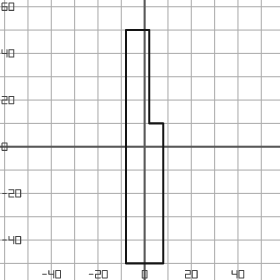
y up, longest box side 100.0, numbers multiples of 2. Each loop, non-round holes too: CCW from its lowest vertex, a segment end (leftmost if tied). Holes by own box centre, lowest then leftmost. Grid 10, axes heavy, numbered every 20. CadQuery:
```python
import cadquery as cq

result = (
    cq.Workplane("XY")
    .moveTo(-8.0, -50.0)
    .lineTo(8.0, -50.0)
    .lineTo(8.0, 10.0)
    .lineTo(2.0, 10.0)
    .lineTo(2.0, 50.0)
    .lineTo(-8.0, 50.0)
    .close()
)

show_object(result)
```